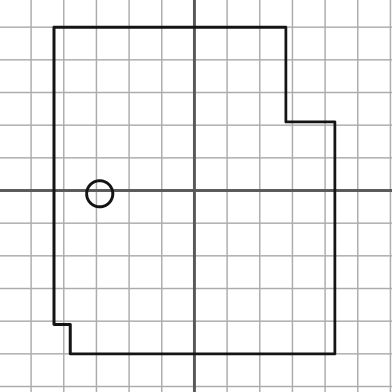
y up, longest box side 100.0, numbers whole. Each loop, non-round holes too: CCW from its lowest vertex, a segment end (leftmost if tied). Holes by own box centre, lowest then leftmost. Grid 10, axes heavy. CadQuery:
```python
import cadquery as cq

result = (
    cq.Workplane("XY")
    .moveTo(-38.0, -50.0)
    .lineTo(43.0, -50.0)
    .lineTo(43.0, 21.0)
    .lineTo(28.0, 21.0)
    .lineTo(28.0, 50.0)
    .lineTo(-43.0, 50.0)
    .lineTo(-43.0, -41.0)
    .lineTo(-38.0, -41.0)
    .close()
    .moveTo(-29.0, -1.0)
    .circle(4.0)
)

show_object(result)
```